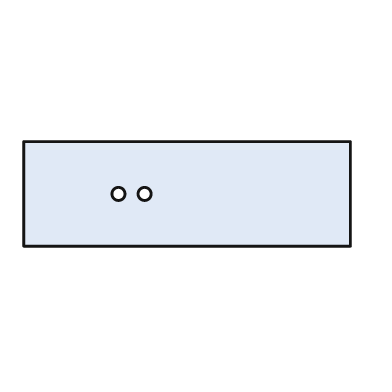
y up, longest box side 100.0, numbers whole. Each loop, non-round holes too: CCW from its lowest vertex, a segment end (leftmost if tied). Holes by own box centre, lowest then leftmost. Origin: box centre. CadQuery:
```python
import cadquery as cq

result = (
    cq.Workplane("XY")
    .moveTo(-50.0, -16.0)
    .lineTo(50.0, -16.0)
    .lineTo(50.0, 16.0)
    .lineTo(-50.0, 16.0)
    .close()
    .moveTo(-21.0, 0.0)
    .circle(2.0)
    .moveTo(-13.0, 0.0)
    .circle(2.0)
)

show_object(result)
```